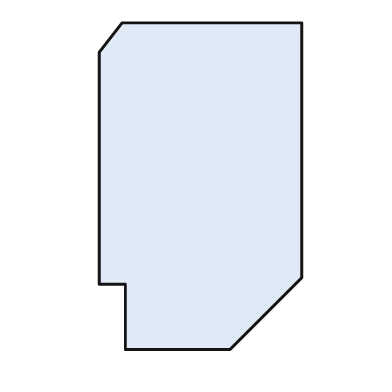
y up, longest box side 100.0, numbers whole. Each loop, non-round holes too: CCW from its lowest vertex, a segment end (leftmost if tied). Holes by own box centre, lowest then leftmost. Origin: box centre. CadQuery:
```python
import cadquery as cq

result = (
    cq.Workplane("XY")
    .moveTo(-23.0, -50.0)
    .lineTo(9.0, -50.0)
    .lineTo(31.0, -28.0)
    .lineTo(31.0, 50.0)
    .lineTo(-24.0, 50.0)
    .lineTo(-31.0, 41.0)
    .lineTo(-31.0, -30.0)
    .lineTo(-23.0, -30.0)
    .close()
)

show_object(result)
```